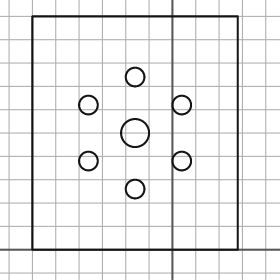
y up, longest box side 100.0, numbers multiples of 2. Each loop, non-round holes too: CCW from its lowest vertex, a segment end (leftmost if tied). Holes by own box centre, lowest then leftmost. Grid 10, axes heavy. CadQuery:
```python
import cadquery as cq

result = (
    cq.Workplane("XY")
    .moveTo(-60.0, 0.0)
    .lineTo(28.0, 0.0)
    .lineTo(28.0, 100.0)
    .lineTo(-60.0, 100.0)
    .close()
    .moveTo(-16.0, 26.0)
    .circle(4.0)
    .moveTo(-36.0, 38.0)
    .circle(4.0)
    .moveTo(4.0, 38.0)
    .circle(4.0)
    .moveTo(-16.0, 50.0)
    .circle(6.0)
    .moveTo(-36.0, 62.0)
    .circle(4.0)
    .moveTo(4.0, 62.0)
    .circle(4.0)
    .moveTo(-16.0, 74.0)
    .circle(4.0)
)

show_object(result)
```